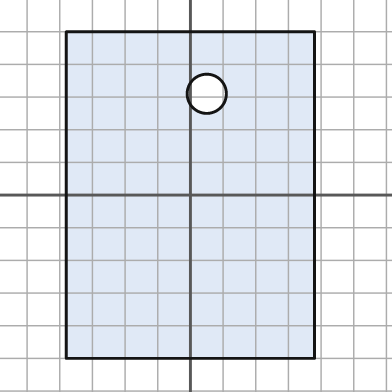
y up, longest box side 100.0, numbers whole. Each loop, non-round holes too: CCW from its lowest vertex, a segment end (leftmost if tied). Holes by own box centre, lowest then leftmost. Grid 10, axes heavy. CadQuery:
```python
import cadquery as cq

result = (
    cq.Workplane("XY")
    .moveTo(-38.0, -50.0)
    .lineTo(38.0, -50.0)
    .lineTo(38.0, 50.0)
    .lineTo(-38.0, 50.0)
    .close()
    .moveTo(5.0, 31.0)
    .circle(6.0)
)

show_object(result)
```